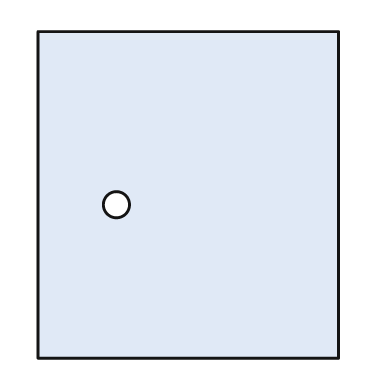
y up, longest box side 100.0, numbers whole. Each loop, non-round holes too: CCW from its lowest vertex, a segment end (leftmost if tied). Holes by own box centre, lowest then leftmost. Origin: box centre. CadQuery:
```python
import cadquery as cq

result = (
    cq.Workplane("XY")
    .moveTo(-46.0, -50.0)
    .lineTo(46.0, -50.0)
    .lineTo(46.0, 50.0)
    .lineTo(-46.0, 50.0)
    .close()
    .moveTo(-22.0, -3.0)
    .circle(4.0)
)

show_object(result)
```